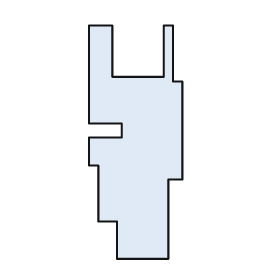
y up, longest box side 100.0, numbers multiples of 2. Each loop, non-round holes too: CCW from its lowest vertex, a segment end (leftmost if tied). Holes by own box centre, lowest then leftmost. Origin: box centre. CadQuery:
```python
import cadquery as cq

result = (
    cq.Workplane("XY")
    .moveTo(-8.0, -50.0)
    .lineTo(14.0, -50.0)
    .lineTo(14.0, -16.0)
    .lineTo(20.0, -16.0)
    .lineTo(20.0, 26.0)
    .lineTo(16.0, 26.0)
    .lineTo(16.0, 50.0)
    .lineTo(12.0, 50.0)
    .lineTo(12.0, 28.0)
    .lineTo(-10.0, 28.0)
    .lineTo(-10.0, 50.0)
    .lineTo(-20.0, 50.0)
    .lineTo(-20.0, 8.0)
    .lineTo(-6.0, 8.0)
    .lineTo(-6.0, 2.0)
    .lineTo(-20.0, 2.0)
    .lineTo(-20.0, -10.0)
    .lineTo(-16.0, -10.0)
    .lineTo(-16.0, -34.0)
    .lineTo(-8.0, -34.0)
    .close()
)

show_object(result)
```